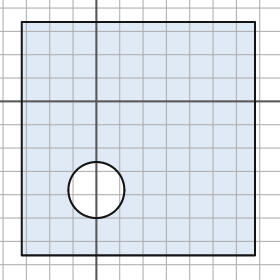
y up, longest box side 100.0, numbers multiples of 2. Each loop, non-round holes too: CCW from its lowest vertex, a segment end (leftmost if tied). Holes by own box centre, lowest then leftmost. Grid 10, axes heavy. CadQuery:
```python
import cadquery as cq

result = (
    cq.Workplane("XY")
    .moveTo(-32.0, -66.0)
    .lineTo(68.0, -66.0)
    .lineTo(68.0, 34.0)
    .lineTo(-32.0, 34.0)
    .close()
    .moveTo(0.0, -38.0)
    .circle(12.0)
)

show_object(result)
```